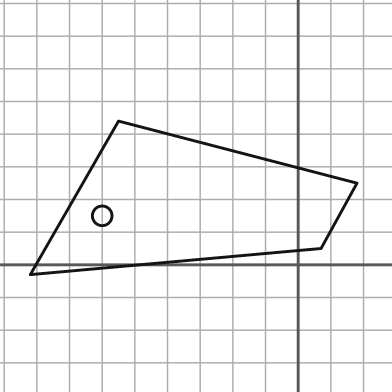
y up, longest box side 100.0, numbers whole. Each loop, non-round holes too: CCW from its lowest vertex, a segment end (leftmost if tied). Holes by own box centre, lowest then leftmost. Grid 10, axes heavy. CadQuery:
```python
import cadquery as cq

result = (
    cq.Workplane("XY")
    .moveTo(-82.0, -3.0)
    .lineTo(7.0, 5.0)
    .lineTo(18.0, 25.0)
    .lineTo(-55.0, 44.0)
    .close()
    .moveTo(-60.0, 15.0)
    .circle(3.0)
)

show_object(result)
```